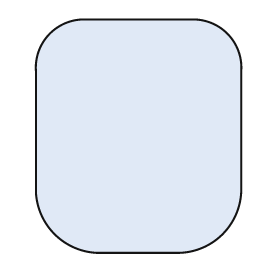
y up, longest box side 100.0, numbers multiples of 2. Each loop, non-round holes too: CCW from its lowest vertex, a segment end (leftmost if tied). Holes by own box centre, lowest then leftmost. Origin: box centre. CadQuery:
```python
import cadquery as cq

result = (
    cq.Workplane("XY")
    .moveTo(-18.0, -50.0)
    .lineTo(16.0, -50.0)
    .threePointArc((36.0, -42.0), (44.0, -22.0))
    .lineTo(44.0, 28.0)
    .threePointArc((38.0, 44.0), (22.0, 50.0))
    .lineTo(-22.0, 50.0)
    .threePointArc((-38.0, 44.0), (-44.0, 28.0))
    .lineTo(-44.0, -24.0)
    .threePointArc((-36.0, -42.0), (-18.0, -50.0))
    .close()
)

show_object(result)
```